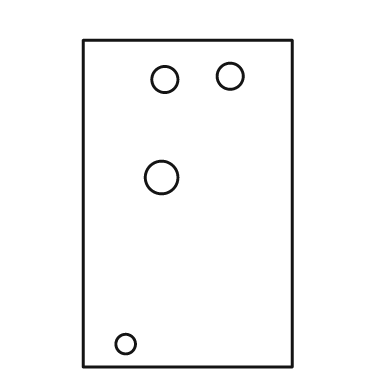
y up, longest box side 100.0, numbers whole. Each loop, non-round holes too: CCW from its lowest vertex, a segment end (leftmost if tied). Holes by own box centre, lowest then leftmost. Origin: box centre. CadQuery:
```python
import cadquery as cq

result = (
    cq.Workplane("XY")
    .moveTo(-32.0, -50.0)
    .lineTo(32.0, -50.0)
    .lineTo(32.0, 50.0)
    .lineTo(-32.0, 50.0)
    .close()
    .moveTo(-19.0, -43.0)
    .circle(3.0)
    .moveTo(-8.0, 8.0)
    .circle(5.0)
    .moveTo(-7.0, 38.0)
    .circle(4.0)
    .moveTo(13.0, 39.0)
    .circle(4.0)
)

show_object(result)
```